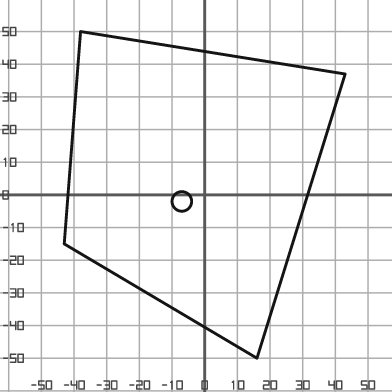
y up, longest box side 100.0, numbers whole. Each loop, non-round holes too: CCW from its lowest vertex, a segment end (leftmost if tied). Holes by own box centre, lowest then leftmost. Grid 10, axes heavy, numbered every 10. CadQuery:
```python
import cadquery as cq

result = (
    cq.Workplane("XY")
    .moveTo(16.0, -50.0)
    .lineTo(43.0, 37.0)
    .lineTo(-38.0, 50.0)
    .lineTo(-43.0, -15.0)
    .close()
    .moveTo(-7.0, -2.0)
    .circle(3.0)
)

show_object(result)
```